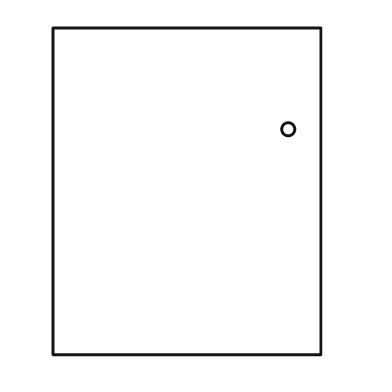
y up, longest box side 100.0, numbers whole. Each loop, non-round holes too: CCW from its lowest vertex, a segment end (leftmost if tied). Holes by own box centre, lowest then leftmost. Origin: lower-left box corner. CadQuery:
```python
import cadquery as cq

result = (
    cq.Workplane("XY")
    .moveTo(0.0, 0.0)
    .lineTo(82.0, 0.0)
    .lineTo(82.0, 100.0)
    .lineTo(0.0, 100.0)
    .close()
    .moveTo(72.0, 69.0)
    .circle(2.0)
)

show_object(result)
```